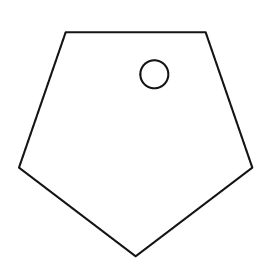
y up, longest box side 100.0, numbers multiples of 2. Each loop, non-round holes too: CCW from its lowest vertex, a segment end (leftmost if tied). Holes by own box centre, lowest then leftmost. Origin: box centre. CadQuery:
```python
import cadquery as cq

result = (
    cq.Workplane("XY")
    .moveTo(0.0, -48.0)
    .lineTo(50.0, -10.0)
    .lineTo(30.0, 48.0)
    .lineTo(-30.0, 48.0)
    .lineTo(-50.0, -10.0)
    .close()
    .moveTo(8.0, 30.0)
    .circle(6.0)
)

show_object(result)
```